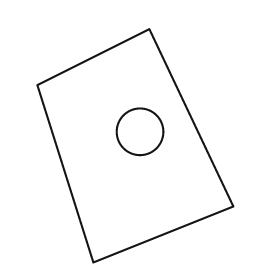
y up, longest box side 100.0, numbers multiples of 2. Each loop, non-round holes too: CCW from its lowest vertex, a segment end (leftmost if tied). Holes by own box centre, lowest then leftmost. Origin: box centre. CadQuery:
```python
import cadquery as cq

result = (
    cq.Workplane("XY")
    .moveTo(-18.0, -50.0)
    .lineTo(42.0, -26.0)
    .lineTo(6.0, 50.0)
    .lineTo(-42.0, 26.0)
    .close()
    .moveTo(2.0, 6.0)
    .circle(10.0)
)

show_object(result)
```